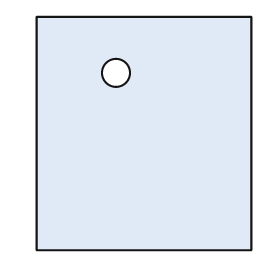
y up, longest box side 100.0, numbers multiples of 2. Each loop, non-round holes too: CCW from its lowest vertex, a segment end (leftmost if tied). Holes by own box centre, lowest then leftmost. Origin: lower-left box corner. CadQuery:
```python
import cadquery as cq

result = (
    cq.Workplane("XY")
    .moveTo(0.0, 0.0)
    .lineTo(92.0, 0.0)
    .lineTo(92.0, 100.0)
    .lineTo(0.0, 100.0)
    .close()
    .moveTo(34.0, 76.0)
    .circle(6.0)
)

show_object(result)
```